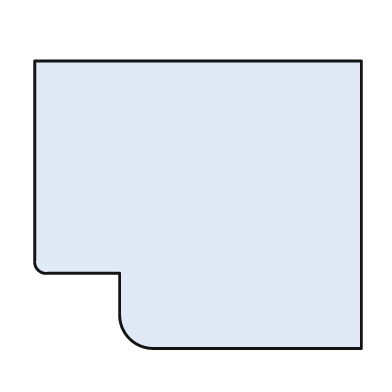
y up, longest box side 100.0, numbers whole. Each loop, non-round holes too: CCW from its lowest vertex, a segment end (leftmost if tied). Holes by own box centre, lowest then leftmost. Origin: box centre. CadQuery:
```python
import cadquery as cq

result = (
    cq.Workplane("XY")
    .moveTo(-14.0, -44.0)
    .lineTo(50.0, -44.0)
    .lineTo(50.0, 44.0)
    .lineTo(-50.0, 44.0)
    .lineTo(-50.0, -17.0)
    .threePointArc((-49.0, -20.0), (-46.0, -21.0))
    .lineTo(-24.0, -21.0)
    .lineTo(-24.0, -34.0)
    .threePointArc((-21.0, -41.0), (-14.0, -44.0))
    .close()
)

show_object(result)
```